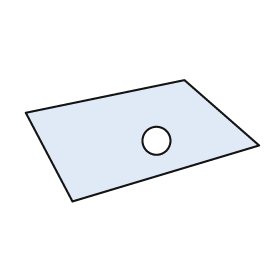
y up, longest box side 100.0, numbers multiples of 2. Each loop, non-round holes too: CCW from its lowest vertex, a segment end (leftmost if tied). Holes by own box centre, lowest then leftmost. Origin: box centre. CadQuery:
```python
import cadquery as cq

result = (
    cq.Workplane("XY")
    .moveTo(-30.0, -26.0)
    .lineTo(50.0, -2.0)
    .lineTo(18.0, 26.0)
    .lineTo(-50.0, 12.0)
    .close()
    .moveTo(6.0, 0.0)
    .circle(6.0)
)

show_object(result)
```